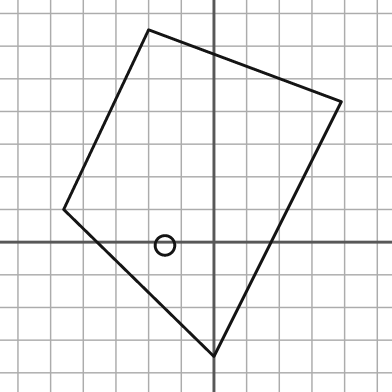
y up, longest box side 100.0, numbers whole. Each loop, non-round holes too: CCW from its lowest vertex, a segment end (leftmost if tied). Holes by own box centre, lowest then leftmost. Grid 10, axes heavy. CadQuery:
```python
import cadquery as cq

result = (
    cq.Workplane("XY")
    .moveTo(0.0, -35.0)
    .lineTo(39.0, 43.0)
    .lineTo(-20.0, 65.0)
    .lineTo(-46.0, 10.0)
    .close()
    .moveTo(-15.0, -1.0)
    .circle(3.0)
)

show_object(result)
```